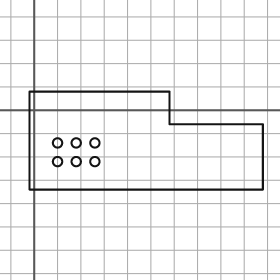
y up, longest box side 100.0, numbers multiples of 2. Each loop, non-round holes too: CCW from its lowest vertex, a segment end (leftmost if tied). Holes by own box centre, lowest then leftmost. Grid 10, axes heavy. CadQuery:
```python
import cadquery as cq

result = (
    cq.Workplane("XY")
    .moveTo(-2.0, -34.0)
    .lineTo(98.0, -34.0)
    .lineTo(98.0, -6.0)
    .lineTo(58.0, -6.0)
    .lineTo(58.0, 8.0)
    .lineTo(-2.0, 8.0)
    .close()
    .moveTo(10.0, -22.0)
    .circle(2.0)
    .moveTo(18.0, -22.0)
    .circle(2.0)
    .moveTo(26.0, -22.0)
    .circle(2.0)
    .moveTo(10.0, -14.0)
    .circle(2.0)
    .moveTo(18.0, -14.0)
    .circle(2.0)
    .moveTo(26.0, -14.0)
    .circle(2.0)
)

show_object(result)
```